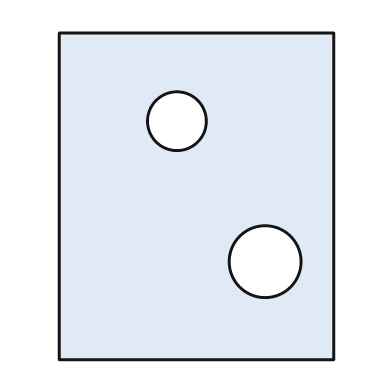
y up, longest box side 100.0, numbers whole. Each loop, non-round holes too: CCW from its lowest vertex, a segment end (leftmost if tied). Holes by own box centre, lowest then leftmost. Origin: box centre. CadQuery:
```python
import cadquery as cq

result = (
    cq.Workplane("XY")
    .moveTo(-42.0, -50.0)
    .lineTo(42.0, -50.0)
    .lineTo(42.0, 50.0)
    .lineTo(-42.0, 50.0)
    .close()
    .moveTo(21.0, -20.0)
    .circle(11.0)
    .moveTo(-6.0, 23.0)
    .circle(9.0)
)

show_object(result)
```